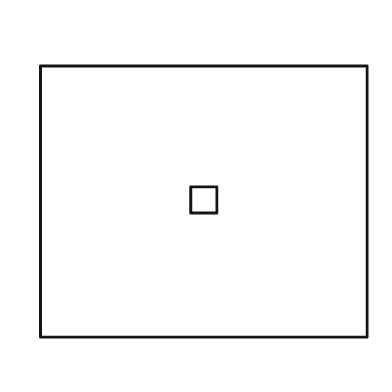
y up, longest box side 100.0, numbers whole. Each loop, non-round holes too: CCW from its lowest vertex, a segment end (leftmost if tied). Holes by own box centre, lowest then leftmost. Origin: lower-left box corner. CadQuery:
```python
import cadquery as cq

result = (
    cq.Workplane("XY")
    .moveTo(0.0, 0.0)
    .lineTo(100.0, 0.0)
    .lineTo(100.0, 83.0)
    .lineTo(0.0, 83.0)
    .close()
    .moveTo(46.0, 38.0)
    .lineTo(54.0, 38.0)
    .lineTo(54.0, 46.0)
    .lineTo(46.0, 46.0)
    .close()
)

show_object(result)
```